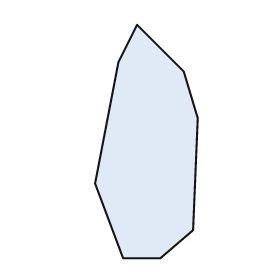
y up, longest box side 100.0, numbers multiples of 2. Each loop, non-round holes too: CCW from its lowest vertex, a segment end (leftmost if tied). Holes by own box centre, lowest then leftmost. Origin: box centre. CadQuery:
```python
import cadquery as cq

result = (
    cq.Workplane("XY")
    .moveTo(-10.0, -50.0)
    .lineTo(6.0, -50.0)
    .lineTo(20.0, -38.0)
    .lineTo(22.0, 10.0)
    .lineTo(16.0, 30.0)
    .lineTo(-4.0, 50.0)
    .lineTo(-12.0, 34.0)
    .lineTo(-22.0, -18.0)
    .close()
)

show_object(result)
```